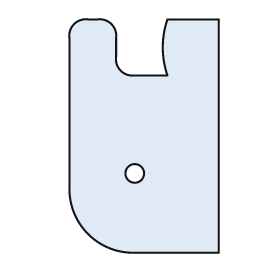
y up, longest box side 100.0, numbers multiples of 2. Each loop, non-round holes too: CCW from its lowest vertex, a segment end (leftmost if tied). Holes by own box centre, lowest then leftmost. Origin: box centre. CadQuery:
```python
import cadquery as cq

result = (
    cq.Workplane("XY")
    .moveTo(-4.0, -50.0)
    .lineTo(32.0, -50.0)
    .lineTo(32.0, 50.0)
    .lineTo(10.0, 50.0)
    .threePointArc((8.0, 38.0), (10.0, 26.0))
    .lineTo(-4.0, 26.0)
    .threePointArc((-10.0, 28.0), (-12.0, 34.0))
    .lineTo(-12.0, 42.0)
    .threePointArc((-14.0, 48.0), (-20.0, 50.0))
    .lineTo(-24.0, 50.0)
    .threePointArc((-30.0, 48.0), (-32.0, 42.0))
    .lineTo(-32.0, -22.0)
    .threePointArc((-24.0, -42.0), (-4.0, -50.0))
    .close()
    .moveTo(-4.0, -16.0)
    .circle(4.0)
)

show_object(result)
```